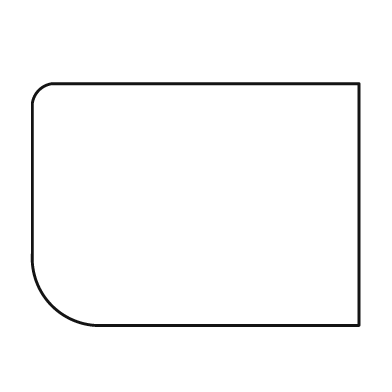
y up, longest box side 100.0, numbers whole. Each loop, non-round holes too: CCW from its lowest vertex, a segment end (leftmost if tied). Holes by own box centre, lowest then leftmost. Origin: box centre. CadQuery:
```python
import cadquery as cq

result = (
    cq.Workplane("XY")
    .moveTo(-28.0, -37.0)
    .lineTo(50.0, -37.0)
    .lineTo(50.0, 37.0)
    .lineTo(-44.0, 37.0)
    .threePointArc((-48.0, 35.0), (-50.0, 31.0))
    .lineTo(-50.0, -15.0)
    .threePointArc((-44.0, -31.0), (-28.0, -37.0))
    .close()
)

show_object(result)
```